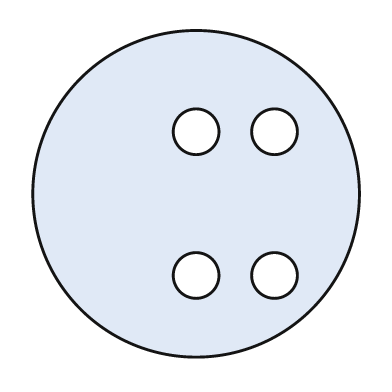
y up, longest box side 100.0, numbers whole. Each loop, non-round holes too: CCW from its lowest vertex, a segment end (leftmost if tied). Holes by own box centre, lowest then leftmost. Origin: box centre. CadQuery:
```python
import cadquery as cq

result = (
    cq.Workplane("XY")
    .moveTo(0.0, 0.0)
    .circle(50.0)
    .moveTo(0.0, -25.0)
    .circle(7.0)
    .moveTo(24.0, -25.0)
    .circle(7.0)
    .moveTo(0.0, 19.0)
    .circle(7.0)
    .moveTo(24.0, 19.0)
    .circle(7.0)
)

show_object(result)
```